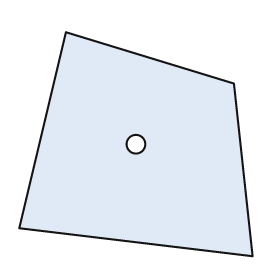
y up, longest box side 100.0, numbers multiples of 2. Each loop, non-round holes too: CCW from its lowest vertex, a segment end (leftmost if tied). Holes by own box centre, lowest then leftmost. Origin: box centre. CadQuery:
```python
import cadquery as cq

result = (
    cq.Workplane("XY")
    .moveTo(50.0, -48.0)
    .lineTo(42.0, 26.0)
    .lineTo(-30.0, 48.0)
    .lineTo(-50.0, -36.0)
    .close()
    .moveTo(0.0, 0.0)
    .circle(4.0)
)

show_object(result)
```